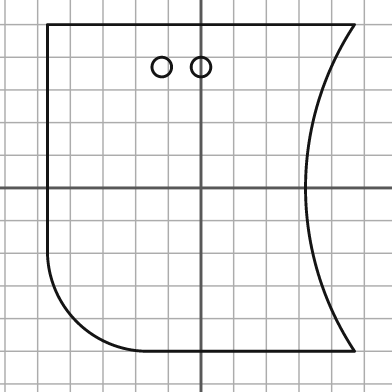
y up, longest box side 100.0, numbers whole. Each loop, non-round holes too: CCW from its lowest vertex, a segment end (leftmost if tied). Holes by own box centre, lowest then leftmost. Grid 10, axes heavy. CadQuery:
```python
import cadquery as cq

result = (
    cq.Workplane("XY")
    .moveTo(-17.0, -50.0)
    .lineTo(47.0, -50.0)
    .threePointArc((32.0, 0.0), (47.0, 50.0))
    .lineTo(-47.0, 50.0)
    .lineTo(-47.0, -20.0)
    .threePointArc((-38.0, -41.0), (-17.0, -50.0))
    .close()
    .moveTo(-12.0, 37.0)
    .circle(3.0)
    .moveTo(0.0, 37.0)
    .circle(3.0)
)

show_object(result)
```